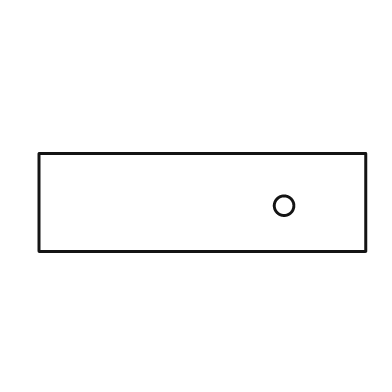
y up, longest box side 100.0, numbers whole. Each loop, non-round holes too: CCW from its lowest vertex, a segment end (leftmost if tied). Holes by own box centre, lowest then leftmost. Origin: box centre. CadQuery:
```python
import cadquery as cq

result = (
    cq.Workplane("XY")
    .moveTo(-50.0, -15.0)
    .lineTo(50.0, -15.0)
    .lineTo(50.0, 15.0)
    .lineTo(-50.0, 15.0)
    .close()
    .moveTo(25.0, -1.0)
    .circle(3.0)
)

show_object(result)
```